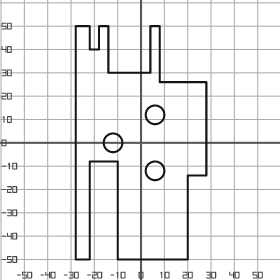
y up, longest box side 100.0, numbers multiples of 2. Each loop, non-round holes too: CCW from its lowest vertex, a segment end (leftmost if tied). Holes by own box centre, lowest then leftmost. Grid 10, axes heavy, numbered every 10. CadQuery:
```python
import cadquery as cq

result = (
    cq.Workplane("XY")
    .moveTo(-28.0, -50.0)
    .lineTo(-22.0, -50.0)
    .lineTo(-22.0, -8.0)
    .lineTo(-10.0, -8.0)
    .lineTo(-10.0, -50.0)
    .lineTo(20.0, -50.0)
    .lineTo(20.0, -14.0)
    .lineTo(28.0, -14.0)
    .lineTo(28.0, 26.0)
    .lineTo(8.0, 26.0)
    .lineTo(8.0, 50.0)
    .lineTo(4.0, 50.0)
    .lineTo(4.0, 30.0)
    .lineTo(-14.0, 30.0)
    .lineTo(-14.0, 50.0)
    .lineTo(-18.0, 50.0)
    .lineTo(-18.0, 40.0)
    .lineTo(-22.0, 40.0)
    .lineTo(-22.0, 50.0)
    .lineTo(-28.0, 50.0)
    .close()
    .moveTo(6.0, -12.0)
    .circle(4.0)
    .moveTo(-12.0, 0.0)
    .circle(4.0)
    .moveTo(6.0, 12.0)
    .circle(4.0)
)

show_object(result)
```